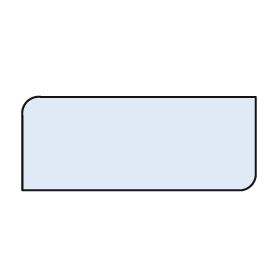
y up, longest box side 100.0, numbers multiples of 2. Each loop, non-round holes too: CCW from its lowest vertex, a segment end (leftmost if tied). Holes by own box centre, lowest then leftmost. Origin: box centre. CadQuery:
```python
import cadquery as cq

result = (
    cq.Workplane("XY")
    .moveTo(-50.0, -20.0)
    .lineTo(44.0, -20.0)
    .threePointArc((48.0, -18.0), (50.0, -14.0))
    .lineTo(50.0, 20.0)
    .lineTo(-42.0, 20.0)
    .threePointArc((-48.0, 18.0), (-50.0, 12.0))
    .close()
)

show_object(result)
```